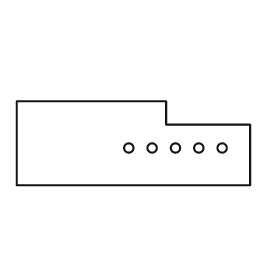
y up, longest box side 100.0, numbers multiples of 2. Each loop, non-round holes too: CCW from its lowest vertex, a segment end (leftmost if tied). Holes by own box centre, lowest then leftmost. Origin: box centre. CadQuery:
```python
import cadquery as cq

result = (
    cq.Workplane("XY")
    .moveTo(-50.0, -18.0)
    .lineTo(50.0, -18.0)
    .lineTo(50.0, 8.0)
    .lineTo(14.0, 8.0)
    .lineTo(14.0, 18.0)
    .lineTo(-50.0, 18.0)
    .close()
    .moveTo(-2.0, -2.0)
    .circle(2.0)
    .moveTo(8.0, -2.0)
    .circle(2.0)
    .moveTo(18.0, -2.0)
    .circle(2.0)
    .moveTo(28.0, -2.0)
    .circle(2.0)
    .moveTo(38.0, -2.0)
    .circle(2.0)
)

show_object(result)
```